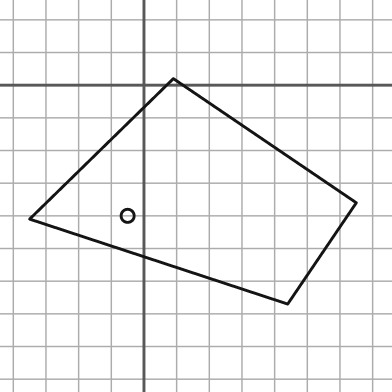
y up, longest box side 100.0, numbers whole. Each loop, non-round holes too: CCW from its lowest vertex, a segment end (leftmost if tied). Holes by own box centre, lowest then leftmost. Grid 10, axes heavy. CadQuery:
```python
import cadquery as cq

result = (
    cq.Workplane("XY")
    .moveTo(44.0, -67.0)
    .lineTo(65.0, -36.0)
    .lineTo(9.0, 2.0)
    .lineTo(-35.0, -41.0)
    .close()
    .moveTo(-5.0, -40.0)
    .circle(2.0)
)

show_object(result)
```